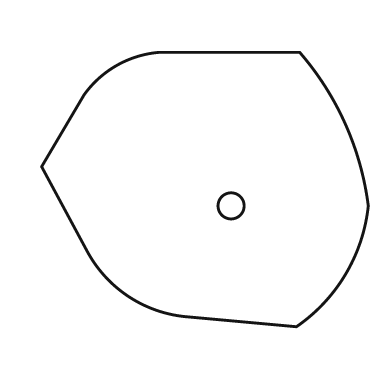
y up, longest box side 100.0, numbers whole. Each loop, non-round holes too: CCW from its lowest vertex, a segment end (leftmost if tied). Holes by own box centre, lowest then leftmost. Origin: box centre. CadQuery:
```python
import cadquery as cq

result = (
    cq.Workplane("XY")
    .moveTo(28.0, -42.0)
    .threePointArc((43.0, -26.0), (50.0, -5.0))
    .threePointArc((43.0, 20.0), (29.0, 42.0))
    .lineTo(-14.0, 42.0)
    .threePointArc((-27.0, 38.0), (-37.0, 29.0))
    .lineTo(-50.0, 7.0)
    .lineTo(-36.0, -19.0)
    .threePointArc((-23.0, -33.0), (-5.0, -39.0))
    .close()
    .moveTo(8.0, -5.0)
    .circle(4.0)
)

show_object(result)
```